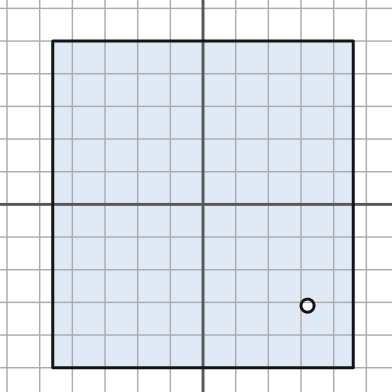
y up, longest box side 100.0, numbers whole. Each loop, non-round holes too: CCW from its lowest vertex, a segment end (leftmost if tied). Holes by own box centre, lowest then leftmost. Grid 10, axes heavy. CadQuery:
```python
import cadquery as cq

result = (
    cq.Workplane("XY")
    .moveTo(-46.0, -50.0)
    .lineTo(46.0, -50.0)
    .lineTo(46.0, 50.0)
    .lineTo(-46.0, 50.0)
    .close()
    .moveTo(32.0, -31.0)
    .circle(2.0)
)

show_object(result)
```